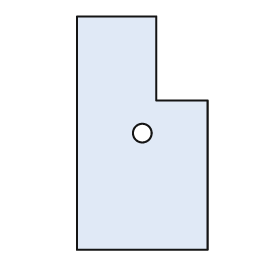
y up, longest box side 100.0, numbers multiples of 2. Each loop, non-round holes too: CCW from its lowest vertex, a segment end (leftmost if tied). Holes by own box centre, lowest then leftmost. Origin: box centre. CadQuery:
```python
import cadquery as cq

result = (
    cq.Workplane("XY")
    .moveTo(-28.0, -50.0)
    .lineTo(28.0, -50.0)
    .lineTo(28.0, 14.0)
    .lineTo(6.0, 14.0)
    .lineTo(6.0, 50.0)
    .lineTo(-28.0, 50.0)
    .close()
    .moveTo(0.0, 0.0)
    .circle(4.0)
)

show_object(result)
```